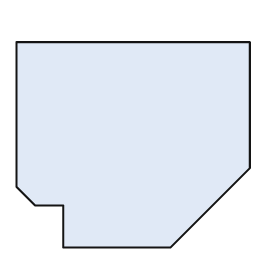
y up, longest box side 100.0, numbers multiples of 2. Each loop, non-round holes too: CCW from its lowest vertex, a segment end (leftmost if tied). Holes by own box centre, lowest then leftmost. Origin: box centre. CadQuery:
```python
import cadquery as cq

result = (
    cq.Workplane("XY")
    .moveTo(-30.0, -44.0)
    .lineTo(16.0, -44.0)
    .lineTo(50.0, -10.0)
    .lineTo(50.0, 44.0)
    .lineTo(-50.0, 44.0)
    .lineTo(-50.0, -18.0)
    .lineTo(-42.0, -26.0)
    .lineTo(-30.0, -26.0)
    .close()
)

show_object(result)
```